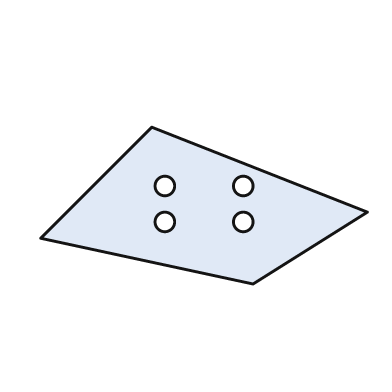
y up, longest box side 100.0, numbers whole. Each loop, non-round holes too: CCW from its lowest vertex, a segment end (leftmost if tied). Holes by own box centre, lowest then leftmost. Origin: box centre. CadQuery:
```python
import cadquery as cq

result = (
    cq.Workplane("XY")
    .moveTo(15.0, -24.0)
    .lineTo(50.0, -2.0)
    .lineTo(-16.0, 24.0)
    .lineTo(-50.0, -10.0)
    .close()
    .moveTo(-12.0, -5.0)
    .circle(3.0)
    .moveTo(12.0, -5.0)
    .circle(3.0)
    .moveTo(-12.0, 6.0)
    .circle(3.0)
    .moveTo(12.0, 6.0)
    .circle(3.0)
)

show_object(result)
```